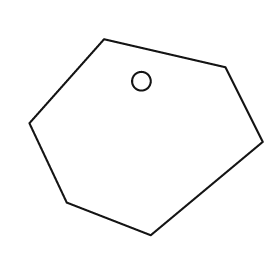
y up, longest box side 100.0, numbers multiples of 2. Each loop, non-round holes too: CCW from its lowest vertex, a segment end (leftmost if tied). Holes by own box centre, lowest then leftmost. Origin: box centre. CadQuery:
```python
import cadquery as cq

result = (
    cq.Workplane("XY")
    .moveTo(2.0, -42.0)
    .lineTo(50.0, -2.0)
    .lineTo(34.0, 30.0)
    .lineTo(-18.0, 42.0)
    .lineTo(-50.0, 6.0)
    .lineTo(-34.0, -28.0)
    .close()
    .moveTo(-2.0, 24.0)
    .circle(4.0)
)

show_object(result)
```